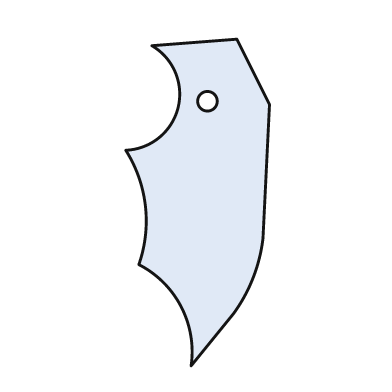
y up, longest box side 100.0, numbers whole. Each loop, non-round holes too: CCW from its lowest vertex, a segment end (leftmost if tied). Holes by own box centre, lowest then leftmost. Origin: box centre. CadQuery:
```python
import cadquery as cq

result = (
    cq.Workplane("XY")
    .moveTo(-2.0, -50.0)
    .lineTo(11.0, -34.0)
    .threePointArc((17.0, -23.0), (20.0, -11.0))
    .lineTo(22.0, 30.0)
    .lineTo(12.0, 50.0)
    .lineTo(-14.0, 48.0)
    .threePointArc((-6.0, 29.0), (-22.0, 16.0))
    .threePointArc((-16.0, -1.0), (-18.0, -19.0))
    .threePointArc((-5.0, -32.0), (-2.0, -50.0))
    .close()
    .moveTo(3.0, 31.0)
    .circle(3.0)
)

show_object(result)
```